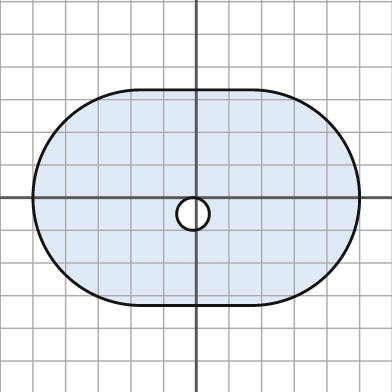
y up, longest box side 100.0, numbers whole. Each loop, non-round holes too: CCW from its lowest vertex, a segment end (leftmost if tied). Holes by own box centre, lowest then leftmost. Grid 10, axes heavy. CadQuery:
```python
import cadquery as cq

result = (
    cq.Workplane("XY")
    .moveTo(-17.0, -33.0)
    .lineTo(17.0, -33.0)
    .threePointArc((50.0, 0.0), (17.0, 33.0))
    .lineTo(-17.0, 33.0)
    .threePointArc((-50.0, 0.0), (-17.0, -33.0))
    .close()
    .moveTo(-1.0, -5.0)
    .circle(5.0)
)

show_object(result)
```